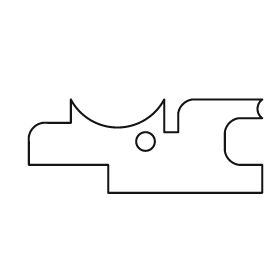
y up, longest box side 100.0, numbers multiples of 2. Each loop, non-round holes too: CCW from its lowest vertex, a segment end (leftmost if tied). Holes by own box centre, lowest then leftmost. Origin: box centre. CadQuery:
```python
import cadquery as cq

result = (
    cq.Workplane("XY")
    .moveTo(-16.0, -20.0)
    .lineTo(50.0, -20.0)
    .lineTo(50.0, -8.0)
    .lineTo(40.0, -8.0)
    .threePointArc((36.0, -6.0), (34.0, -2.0))
    .lineTo(34.0, 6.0)
    .threePointArc((36.0, 10.0), (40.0, 12.0))
    .lineTo(50.0, 12.0)
    .threePointArc((48.0, 16.0), (50.0, 20.0))
    .lineTo(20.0, 20.0)
    .threePointArc((16.0, 18.0), (14.0, 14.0))
    .lineTo(14.0, 6.0)
    .lineTo(8.0, 6.0)
    .lineTo(8.0, 20.0)
    .threePointArc((-12.0, 8.0), (-32.0, 20.0))
    .lineTo(-32.0, 10.0)
    .lineTo(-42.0, 10.0)
    .threePointArc((-48.0, 8.0), (-50.0, 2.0))
    .lineTo(-50.0, -8.0)
    .lineTo(-16.0, -8.0)
    .close()
    .moveTo(0.0, 2.0)
    .circle(4.0)
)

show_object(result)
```